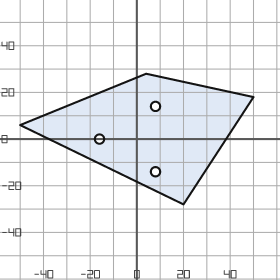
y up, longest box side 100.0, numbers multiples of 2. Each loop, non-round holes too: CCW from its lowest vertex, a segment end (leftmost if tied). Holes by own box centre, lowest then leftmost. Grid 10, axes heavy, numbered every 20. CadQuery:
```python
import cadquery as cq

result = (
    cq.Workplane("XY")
    .moveTo(20.0, -28.0)
    .lineTo(50.0, 18.0)
    .lineTo(4.0, 28.0)
    .lineTo(-50.0, 6.0)
    .close()
    .moveTo(8.0, -14.0)
    .circle(2.0)
    .moveTo(-16.0, 0.0)
    .circle(2.0)
    .moveTo(8.0, 14.0)
    .circle(2.0)
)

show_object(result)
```